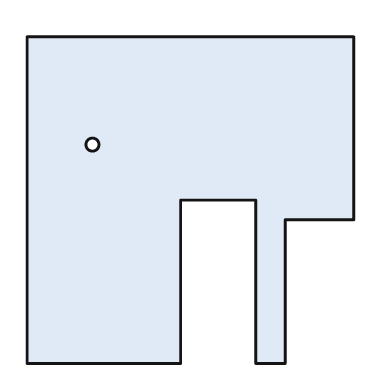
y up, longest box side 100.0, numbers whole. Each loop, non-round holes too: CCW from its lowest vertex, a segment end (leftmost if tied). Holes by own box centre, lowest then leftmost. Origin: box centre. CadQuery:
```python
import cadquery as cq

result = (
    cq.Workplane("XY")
    .moveTo(-50.0, -50.0)
    .lineTo(-3.0, -50.0)
    .lineTo(-3.0, 0.0)
    .lineTo(20.0, 0.0)
    .lineTo(20.0, -50.0)
    .lineTo(29.0, -50.0)
    .lineTo(29.0, -6.0)
    .lineTo(50.0, -6.0)
    .lineTo(50.0, 50.0)
    .lineTo(-50.0, 50.0)
    .close()
    .moveTo(-30.0, 17.0)
    .circle(2.0)
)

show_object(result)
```